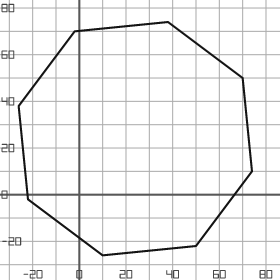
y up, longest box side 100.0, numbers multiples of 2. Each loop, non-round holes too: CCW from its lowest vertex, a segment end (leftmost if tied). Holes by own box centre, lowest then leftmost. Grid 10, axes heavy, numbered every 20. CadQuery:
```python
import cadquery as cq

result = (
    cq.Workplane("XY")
    .moveTo(10.0, -26.0)
    .lineTo(50.0, -22.0)
    .lineTo(74.0, 10.0)
    .lineTo(70.0, 50.0)
    .lineTo(38.0, 74.0)
    .lineTo(-2.0, 70.0)
    .lineTo(-26.0, 38.0)
    .lineTo(-22.0, -2.0)
    .close()
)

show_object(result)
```